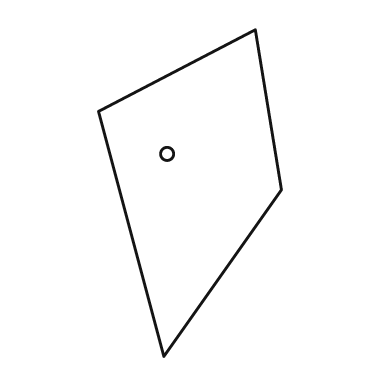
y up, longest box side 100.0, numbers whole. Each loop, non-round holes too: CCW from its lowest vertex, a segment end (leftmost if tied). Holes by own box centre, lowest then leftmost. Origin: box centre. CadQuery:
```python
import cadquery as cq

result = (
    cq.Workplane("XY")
    .moveTo(-8.0, -50.0)
    .lineTo(28.0, 1.0)
    .lineTo(20.0, 50.0)
    .lineTo(-28.0, 25.0)
    .close()
    .moveTo(-7.0, 12.0)
    .circle(2.0)
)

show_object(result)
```